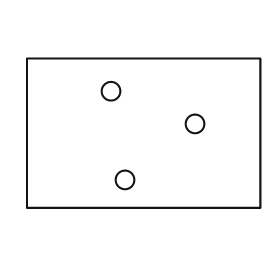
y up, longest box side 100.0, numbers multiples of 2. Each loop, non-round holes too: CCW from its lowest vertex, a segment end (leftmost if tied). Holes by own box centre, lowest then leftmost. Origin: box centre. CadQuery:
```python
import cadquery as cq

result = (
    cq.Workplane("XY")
    .moveTo(-50.0, -32.0)
    .lineTo(50.0, -32.0)
    .lineTo(50.0, 32.0)
    .lineTo(-50.0, 32.0)
    .close()
    .moveTo(-8.0, -20.0)
    .circle(4.0)
    .moveTo(22.0, 4.0)
    .circle(4.0)
    .moveTo(-14.0, 18.0)
    .circle(4.0)
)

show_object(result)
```